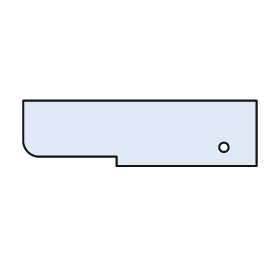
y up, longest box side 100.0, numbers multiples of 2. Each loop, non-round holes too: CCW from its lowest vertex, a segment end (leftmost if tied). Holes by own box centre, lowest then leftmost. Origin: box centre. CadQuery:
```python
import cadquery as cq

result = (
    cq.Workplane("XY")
    .moveTo(-10.0, -14.0)
    .lineTo(50.0, -14.0)
    .lineTo(50.0, 14.0)
    .lineTo(-50.0, 14.0)
    .lineTo(-50.0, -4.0)
    .threePointArc((-48.0, -8.0), (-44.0, -10.0))
    .lineTo(-10.0, -10.0)
    .close()
    .moveTo(36.0, -6.0)
    .circle(2.0)
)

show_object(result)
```